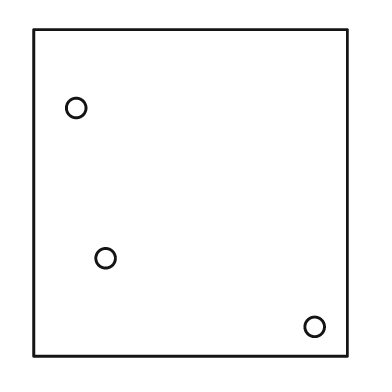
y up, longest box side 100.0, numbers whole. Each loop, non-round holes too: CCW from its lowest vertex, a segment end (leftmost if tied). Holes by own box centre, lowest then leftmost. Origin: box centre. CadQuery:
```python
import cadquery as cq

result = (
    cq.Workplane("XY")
    .moveTo(-48.0, -50.0)
    .lineTo(48.0, -50.0)
    .lineTo(48.0, 50.0)
    .lineTo(-48.0, 50.0)
    .close()
    .moveTo(38.0, -41.0)
    .circle(3.0)
    .moveTo(-26.0, -20.0)
    .circle(3.0)
    .moveTo(-35.0, 26.0)
    .circle(3.0)
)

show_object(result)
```